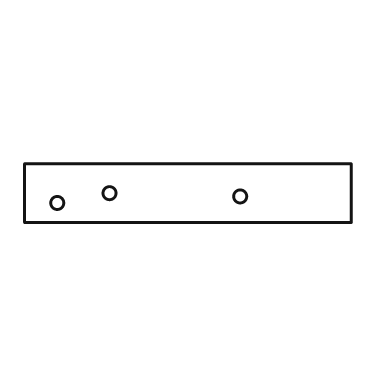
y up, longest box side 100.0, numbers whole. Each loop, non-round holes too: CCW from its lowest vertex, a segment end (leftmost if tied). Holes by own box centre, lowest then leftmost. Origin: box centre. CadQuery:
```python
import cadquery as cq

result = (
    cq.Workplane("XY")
    .moveTo(-50.0, -9.0)
    .lineTo(50.0, -9.0)
    .lineTo(50.0, 9.0)
    .lineTo(-50.0, 9.0)
    .close()
    .moveTo(-40.0, -3.0)
    .circle(2.0)
    .moveTo(16.0, -1.0)
    .circle(2.0)
    .moveTo(-24.0, 0.0)
    .circle(2.0)
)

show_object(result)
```